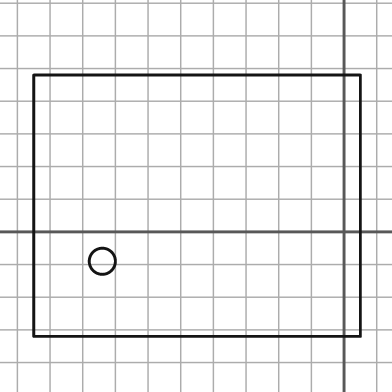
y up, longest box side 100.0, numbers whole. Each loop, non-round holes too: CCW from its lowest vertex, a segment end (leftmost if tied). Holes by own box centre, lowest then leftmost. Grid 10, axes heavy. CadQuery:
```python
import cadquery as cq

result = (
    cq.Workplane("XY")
    .moveTo(-95.0, -32.0)
    .lineTo(5.0, -32.0)
    .lineTo(5.0, 48.0)
    .lineTo(-95.0, 48.0)
    .close()
    .moveTo(-74.0, -9.0)
    .circle(4.0)
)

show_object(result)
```